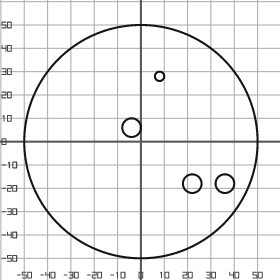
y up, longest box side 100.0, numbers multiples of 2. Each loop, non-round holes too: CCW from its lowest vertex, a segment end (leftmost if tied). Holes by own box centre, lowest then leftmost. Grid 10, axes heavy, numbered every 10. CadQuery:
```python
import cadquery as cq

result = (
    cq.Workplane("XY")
    .moveTo(0.0, 0.0)
    .circle(50.0)
    .moveTo(22.0, -18.0)
    .circle(4.0)
    .moveTo(36.0, -18.0)
    .circle(4.0)
    .moveTo(-4.0, 6.0)
    .circle(4.0)
    .moveTo(8.0, 28.0)
    .circle(2.0)
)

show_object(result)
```